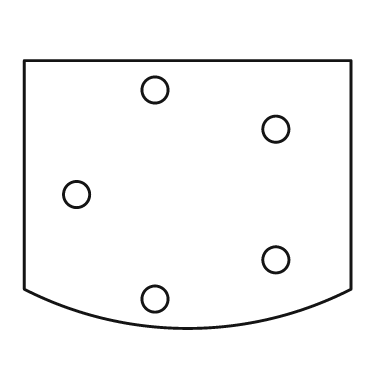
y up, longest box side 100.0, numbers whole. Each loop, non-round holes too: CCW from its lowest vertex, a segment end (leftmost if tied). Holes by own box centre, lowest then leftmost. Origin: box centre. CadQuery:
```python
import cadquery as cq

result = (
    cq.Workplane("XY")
    .moveTo(-50.0, -29.0)
    .threePointArc((0.0, -41.0), (50.0, -29.0))
    .lineTo(50.0, 41.0)
    .lineTo(-50.0, 41.0)
    .close()
    .moveTo(-10.0, -32.0)
    .circle(4.0)
    .moveTo(27.0, -20.0)
    .circle(4.0)
    .moveTo(-34.0, 0.0)
    .circle(4.0)
    .moveTo(27.0, 20.0)
    .circle(4.0)
    .moveTo(-10.0, 32.0)
    .circle(4.0)
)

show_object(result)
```